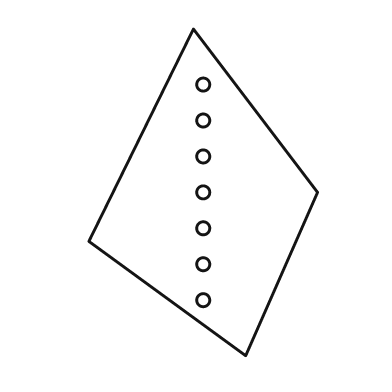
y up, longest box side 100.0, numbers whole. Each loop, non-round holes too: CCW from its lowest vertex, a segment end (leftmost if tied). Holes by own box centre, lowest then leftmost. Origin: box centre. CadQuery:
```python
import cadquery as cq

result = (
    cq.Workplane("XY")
    .moveTo(13.0, -50.0)
    .lineTo(35.0, 0.0)
    .lineTo(-3.0, 50.0)
    .lineTo(-35.0, -15.0)
    .close()
    .moveTo(0.0, -33.0)
    .circle(2.0)
    .moveTo(0.0, -22.0)
    .circle(2.0)
    .moveTo(0.0, -11.0)
    .circle(2.0)
    .moveTo(0.0, 0.0)
    .circle(2.0)
    .moveTo(0.0, 11.0)
    .circle(2.0)
    .moveTo(0.0, 22.0)
    .circle(2.0)
    .moveTo(0.0, 33.0)
    .circle(2.0)
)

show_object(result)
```